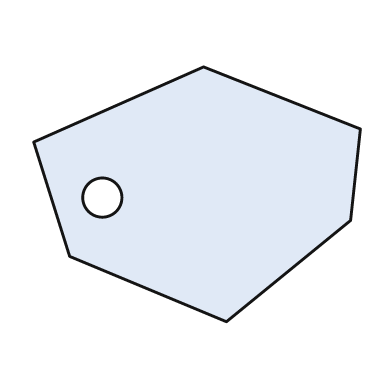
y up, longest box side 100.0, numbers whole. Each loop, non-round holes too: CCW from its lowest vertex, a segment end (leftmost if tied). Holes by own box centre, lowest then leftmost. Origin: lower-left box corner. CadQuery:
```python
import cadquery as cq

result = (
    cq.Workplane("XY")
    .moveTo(59.0, 0.0)
    .lineTo(97.0, 31.0)
    .lineTo(100.0, 59.0)
    .lineTo(52.0, 78.0)
    .lineTo(0.0, 55.0)
    .lineTo(11.0, 20.0)
    .close()
    .moveTo(21.0, 38.0)
    .circle(6.0)
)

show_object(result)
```